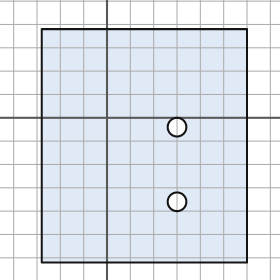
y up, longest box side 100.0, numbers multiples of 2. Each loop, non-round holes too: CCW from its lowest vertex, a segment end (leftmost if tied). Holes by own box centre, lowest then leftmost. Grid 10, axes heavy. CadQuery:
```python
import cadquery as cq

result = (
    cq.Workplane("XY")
    .moveTo(-28.0, -62.0)
    .lineTo(60.0, -62.0)
    .lineTo(60.0, 38.0)
    .lineTo(-28.0, 38.0)
    .close()
    .moveTo(30.0, -36.0)
    .circle(4.0)
    .moveTo(30.0, -4.0)
    .circle(4.0)
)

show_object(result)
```